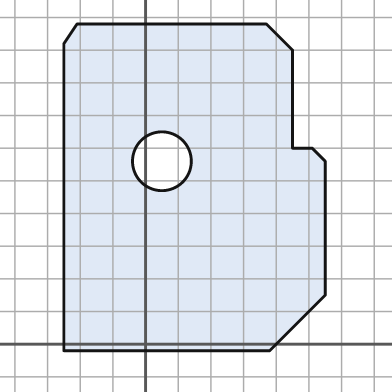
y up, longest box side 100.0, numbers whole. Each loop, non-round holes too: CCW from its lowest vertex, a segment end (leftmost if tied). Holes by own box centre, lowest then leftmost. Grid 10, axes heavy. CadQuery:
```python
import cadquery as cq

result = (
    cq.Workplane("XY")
    .moveTo(-25.0, -2.0)
    .lineTo(38.0, -2.0)
    .lineTo(55.0, 15.0)
    .lineTo(55.0, 56.0)
    .lineTo(51.0, 60.0)
    .lineTo(45.0, 60.0)
    .lineTo(45.0, 90.0)
    .lineTo(37.0, 98.0)
    .lineTo(-21.0, 98.0)
    .lineTo(-25.0, 92.0)
    .close()
    .moveTo(5.0, 56.0)
    .circle(9.0)
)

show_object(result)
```